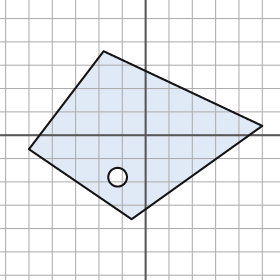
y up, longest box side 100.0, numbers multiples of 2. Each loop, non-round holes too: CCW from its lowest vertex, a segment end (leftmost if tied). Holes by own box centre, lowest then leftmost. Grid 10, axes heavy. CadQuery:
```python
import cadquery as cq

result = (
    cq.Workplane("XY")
    .moveTo(-6.0, -36.0)
    .lineTo(50.0, 4.0)
    .lineTo(-18.0, 36.0)
    .lineTo(-50.0, -6.0)
    .close()
    .moveTo(-12.0, -18.0)
    .circle(4.0)
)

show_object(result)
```